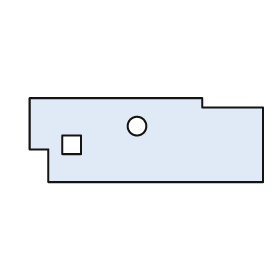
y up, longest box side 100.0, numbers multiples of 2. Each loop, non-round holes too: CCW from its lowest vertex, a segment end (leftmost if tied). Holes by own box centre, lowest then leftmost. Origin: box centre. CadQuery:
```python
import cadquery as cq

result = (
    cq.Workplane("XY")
    .moveTo(-42.0, -18.0)
    .lineTo(50.0, -18.0)
    .lineTo(50.0, 14.0)
    .lineTo(24.0, 14.0)
    .lineTo(24.0, 18.0)
    .lineTo(-50.0, 18.0)
    .lineTo(-50.0, -4.0)
    .lineTo(-42.0, -4.0)
    .close()
    .moveTo(-36.0, -6.0)
    .lineTo(-28.0, -6.0)
    .lineTo(-28.0, 2.0)
    .lineTo(-36.0, 2.0)
    .close()
    .moveTo(-4.0, 6.0)
    .circle(4.0)
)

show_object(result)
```